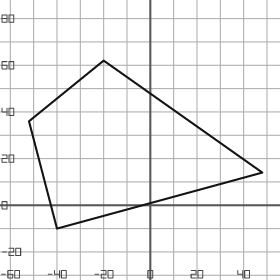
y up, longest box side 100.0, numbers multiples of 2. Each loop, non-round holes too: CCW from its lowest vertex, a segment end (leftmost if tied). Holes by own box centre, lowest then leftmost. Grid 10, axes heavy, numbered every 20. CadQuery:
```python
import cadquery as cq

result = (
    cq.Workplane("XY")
    .moveTo(-40.0, -10.0)
    .lineTo(48.0, 14.0)
    .lineTo(-20.0, 62.0)
    .lineTo(-52.0, 36.0)
    .close()
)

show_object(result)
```